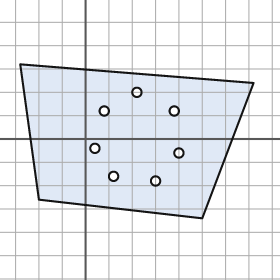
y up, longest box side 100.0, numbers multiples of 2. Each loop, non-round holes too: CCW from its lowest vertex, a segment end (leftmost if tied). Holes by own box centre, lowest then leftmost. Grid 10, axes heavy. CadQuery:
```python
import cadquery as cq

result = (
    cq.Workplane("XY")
    .moveTo(50.0, -34.0)
    .lineTo(72.0, 24.0)
    .lineTo(-28.0, 32.0)
    .lineTo(-20.0, -26.0)
    .close()
    .moveTo(30.0, -18.0)
    .circle(2.0)
    .moveTo(12.0, -16.0)
    .circle(2.0)
    .moveTo(40.0, -6.0)
    .circle(2.0)
    .moveTo(4.0, -4.0)
    .circle(2.0)
    .moveTo(8.0, 12.0)
    .circle(2.0)
    .moveTo(38.0, 12.0)
    .circle(2.0)
    .moveTo(22.0, 20.0)
    .circle(2.0)
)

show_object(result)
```